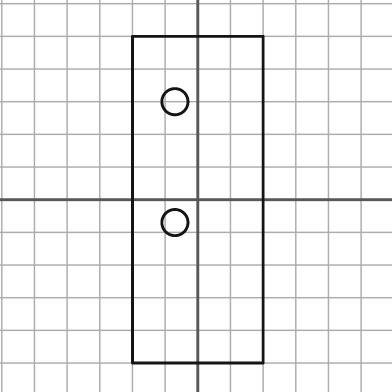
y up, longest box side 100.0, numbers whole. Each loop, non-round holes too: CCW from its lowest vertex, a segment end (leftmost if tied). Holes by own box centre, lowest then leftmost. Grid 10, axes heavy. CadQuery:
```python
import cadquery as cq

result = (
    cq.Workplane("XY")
    .moveTo(-20.0, -50.0)
    .lineTo(20.0, -50.0)
    .lineTo(20.0, 50.0)
    .lineTo(-20.0, 50.0)
    .close()
    .moveTo(-7.0, -7.0)
    .circle(4.0)
    .moveTo(-7.0, 30.0)
    .circle(4.0)
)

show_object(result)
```